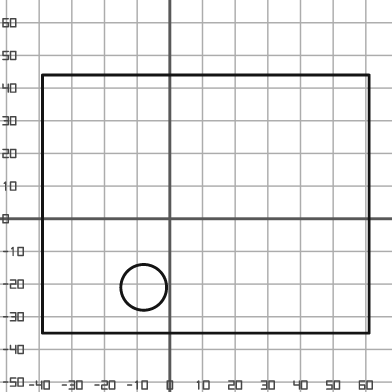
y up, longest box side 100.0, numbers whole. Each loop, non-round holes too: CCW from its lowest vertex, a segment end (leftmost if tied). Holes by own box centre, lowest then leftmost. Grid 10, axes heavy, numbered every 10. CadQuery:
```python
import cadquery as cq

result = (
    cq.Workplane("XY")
    .moveTo(-39.0, -35.0)
    .lineTo(61.0, -35.0)
    .lineTo(61.0, 44.0)
    .lineTo(-39.0, 44.0)
    .close()
    .moveTo(-8.0, -21.0)
    .circle(7.0)
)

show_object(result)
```